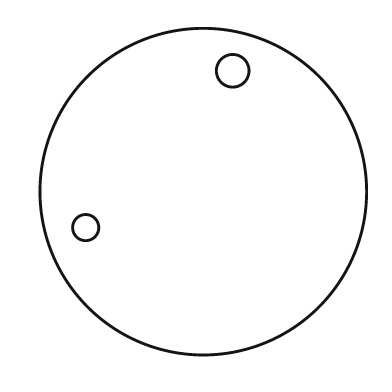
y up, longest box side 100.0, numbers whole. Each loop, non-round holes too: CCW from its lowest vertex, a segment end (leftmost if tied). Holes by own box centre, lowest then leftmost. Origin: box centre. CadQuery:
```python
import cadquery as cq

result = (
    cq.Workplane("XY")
    .moveTo(0.0, 0.0)
    .circle(50.0)
    .moveTo(-36.0, -11.0)
    .circle(4.0)
    .moveTo(9.0, 37.0)
    .circle(5.0)
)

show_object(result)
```